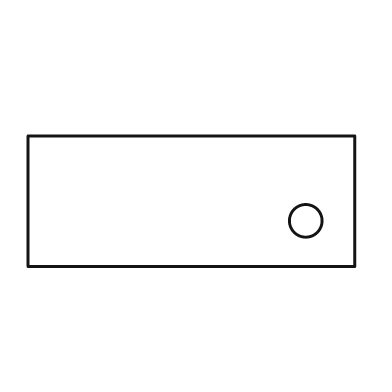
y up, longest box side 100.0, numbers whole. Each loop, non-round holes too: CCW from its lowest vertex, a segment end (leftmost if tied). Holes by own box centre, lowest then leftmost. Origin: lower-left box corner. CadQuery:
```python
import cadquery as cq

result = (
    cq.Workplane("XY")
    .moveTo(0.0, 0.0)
    .lineTo(100.0, 0.0)
    .lineTo(100.0, 40.0)
    .lineTo(0.0, 40.0)
    .close()
    .moveTo(85.0, 14.0)
    .circle(5.0)
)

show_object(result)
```